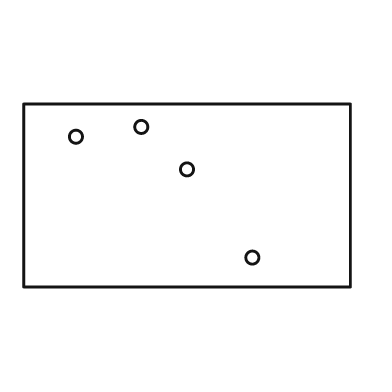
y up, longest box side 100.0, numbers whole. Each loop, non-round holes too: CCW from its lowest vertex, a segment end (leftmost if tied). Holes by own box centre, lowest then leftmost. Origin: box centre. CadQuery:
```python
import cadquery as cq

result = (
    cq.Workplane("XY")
    .moveTo(-50.0, -28.0)
    .lineTo(50.0, -28.0)
    .lineTo(50.0, 28.0)
    .lineTo(-50.0, 28.0)
    .close()
    .moveTo(20.0, -19.0)
    .circle(2.0)
    .moveTo(0.0, 8.0)
    .circle(2.0)
    .moveTo(-34.0, 18.0)
    .circle(2.0)
    .moveTo(-14.0, 21.0)
    .circle(2.0)
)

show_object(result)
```